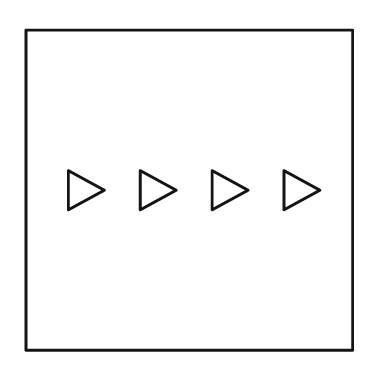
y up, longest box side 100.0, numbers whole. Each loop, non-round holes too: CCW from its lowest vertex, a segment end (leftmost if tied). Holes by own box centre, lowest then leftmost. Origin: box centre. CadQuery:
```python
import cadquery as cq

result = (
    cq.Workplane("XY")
    .moveTo(-50.0, -49.0)
    .lineTo(50.0, -49.0)
    .lineTo(50.0, 49.0)
    .lineTo(-50.0, 49.0)
    .close()
    .moveTo(-37.0, -6.0)
    .lineTo(-26.0, 0.0)
    .lineTo(-37.0, 6.0)
    .close()
    .moveTo(-15.0, -6.0)
    .lineTo(-4.0, 0.0)
    .lineTo(-15.0, 6.0)
    .close()
    .moveTo(7.0, -6.0)
    .lineTo(18.0, 0.0)
    .lineTo(7.0, 6.0)
    .close()
    .moveTo(29.0, -6.0)
    .lineTo(40.0, 0.0)
    .lineTo(29.0, 6.0)
    .close()
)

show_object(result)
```